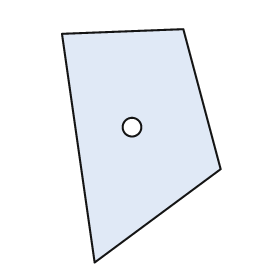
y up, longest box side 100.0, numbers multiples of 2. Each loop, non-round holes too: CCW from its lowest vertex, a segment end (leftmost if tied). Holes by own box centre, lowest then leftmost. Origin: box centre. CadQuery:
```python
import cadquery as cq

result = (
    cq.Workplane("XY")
    .moveTo(-20.0, -50.0)
    .lineTo(34.0, -10.0)
    .lineTo(18.0, 50.0)
    .lineTo(-34.0, 48.0)
    .close()
    .moveTo(-4.0, 8.0)
    .circle(4.0)
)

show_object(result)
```